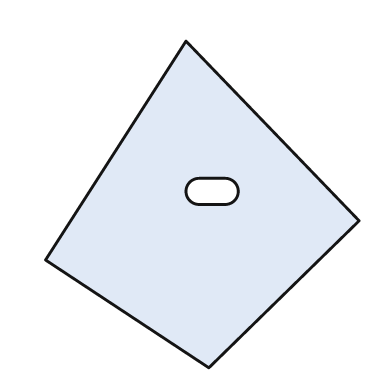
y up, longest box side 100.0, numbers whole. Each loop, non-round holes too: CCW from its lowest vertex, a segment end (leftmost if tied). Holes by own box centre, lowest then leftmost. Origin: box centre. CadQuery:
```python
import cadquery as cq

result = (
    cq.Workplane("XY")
    .moveTo(2.0, -50.0)
    .lineTo(48.0, -5.0)
    .lineTo(-5.0, 50.0)
    .lineTo(-48.0, -17.0)
    .close()
    .moveTo(-1.0, 0.0)
    .lineTo(7.0, 0.0)
    .threePointArc((11.0, 4.0), (7.0, 8.0))
    .lineTo(-1.0, 8.0)
    .threePointArc((-5.0, 4.0), (-1.0, 0.0))
    .close()
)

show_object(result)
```